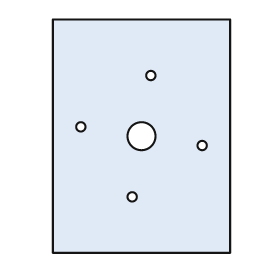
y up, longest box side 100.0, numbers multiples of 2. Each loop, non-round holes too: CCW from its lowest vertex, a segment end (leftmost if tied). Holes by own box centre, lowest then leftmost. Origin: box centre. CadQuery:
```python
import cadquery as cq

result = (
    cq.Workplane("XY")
    .moveTo(-38.0, -50.0)
    .lineTo(38.0, -50.0)
    .lineTo(38.0, 50.0)
    .lineTo(-38.0, 50.0)
    .close()
    .moveTo(-4.0, -26.0)
    .circle(2.0)
    .moveTo(26.0, -4.0)
    .circle(2.0)
    .moveTo(0.0, 0.0)
    .circle(6.0)
    .moveTo(-26.0, 4.0)
    .circle(2.0)
    .moveTo(4.0, 26.0)
    .circle(2.0)
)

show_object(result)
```